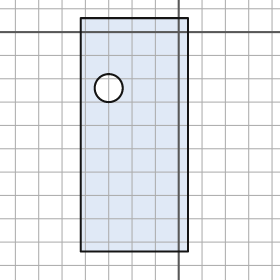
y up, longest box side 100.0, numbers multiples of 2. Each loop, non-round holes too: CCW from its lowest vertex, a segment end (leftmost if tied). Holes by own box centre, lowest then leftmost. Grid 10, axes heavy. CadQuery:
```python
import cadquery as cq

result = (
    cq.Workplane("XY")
    .moveTo(-42.0, -94.0)
    .lineTo(4.0, -94.0)
    .lineTo(4.0, 6.0)
    .lineTo(-42.0, 6.0)
    .close()
    .moveTo(-30.0, -24.0)
    .circle(6.0)
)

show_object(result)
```